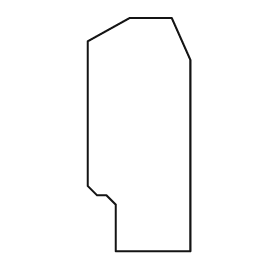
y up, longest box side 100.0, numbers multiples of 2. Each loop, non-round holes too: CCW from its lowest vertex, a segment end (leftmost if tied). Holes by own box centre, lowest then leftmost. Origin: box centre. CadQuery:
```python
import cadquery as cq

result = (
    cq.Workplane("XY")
    .moveTo(-10.0, -50.0)
    .lineTo(22.0, -50.0)
    .lineTo(22.0, 32.0)
    .lineTo(14.0, 50.0)
    .lineTo(-4.0, 50.0)
    .lineTo(-22.0, 40.0)
    .lineTo(-22.0, -22.0)
    .lineTo(-18.0, -26.0)
    .lineTo(-14.0, -26.0)
    .lineTo(-10.0, -30.0)
    .close()
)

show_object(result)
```